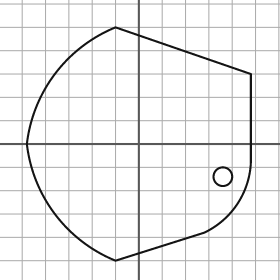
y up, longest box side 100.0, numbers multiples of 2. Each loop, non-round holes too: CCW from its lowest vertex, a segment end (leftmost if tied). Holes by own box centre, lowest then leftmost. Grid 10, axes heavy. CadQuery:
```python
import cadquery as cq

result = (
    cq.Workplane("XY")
    .moveTo(-10.0, -50.0)
    .lineTo(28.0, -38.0)
    .threePointArc((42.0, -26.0), (48.0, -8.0))
    .lineTo(48.0, 30.0)
    .lineTo(-10.0, 50.0)
    .threePointArc((-36.0, 30.0), (-48.0, 0.0))
    .threePointArc((-36.0, -30.0), (-10.0, -50.0))
    .close()
    .moveTo(36.0, -14.0)
    .circle(4.0)
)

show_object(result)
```